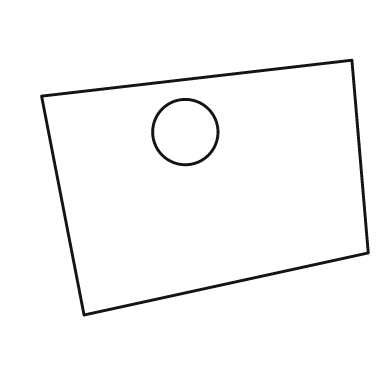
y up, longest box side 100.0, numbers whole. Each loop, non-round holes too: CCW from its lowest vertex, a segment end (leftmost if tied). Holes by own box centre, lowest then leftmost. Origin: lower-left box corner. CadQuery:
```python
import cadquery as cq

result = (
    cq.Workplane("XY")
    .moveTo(13.0, 0.0)
    .lineTo(100.0, 19.0)
    .lineTo(95.0, 78.0)
    .lineTo(0.0, 67.0)
    .close()
    .moveTo(44.0, 56.0)
    .circle(10.0)
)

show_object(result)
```